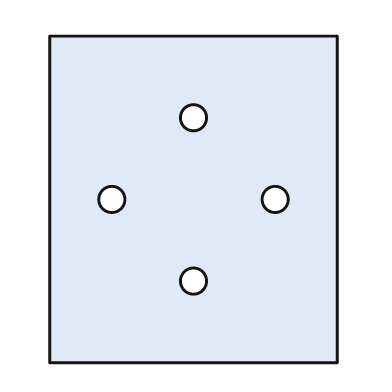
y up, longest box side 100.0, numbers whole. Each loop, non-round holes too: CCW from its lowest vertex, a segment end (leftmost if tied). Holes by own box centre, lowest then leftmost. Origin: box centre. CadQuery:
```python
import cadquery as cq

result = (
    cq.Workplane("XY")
    .moveTo(-44.0, -50.0)
    .lineTo(44.0, -50.0)
    .lineTo(44.0, 50.0)
    .lineTo(-44.0, 50.0)
    .close()
    .moveTo(0.0, -25.0)
    .circle(4.0)
    .moveTo(-25.0, 0.0)
    .circle(4.0)
    .moveTo(25.0, 0.0)
    .circle(4.0)
    .moveTo(0.0, 25.0)
    .circle(4.0)
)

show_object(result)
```